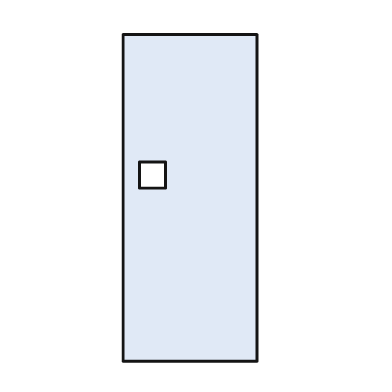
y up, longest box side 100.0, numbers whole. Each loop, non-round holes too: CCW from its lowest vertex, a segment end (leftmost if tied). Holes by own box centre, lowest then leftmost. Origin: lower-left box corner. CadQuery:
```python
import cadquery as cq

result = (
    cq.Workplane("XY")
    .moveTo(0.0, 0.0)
    .lineTo(41.0, 0.0)
    .lineTo(41.0, 100.0)
    .lineTo(0.0, 100.0)
    .close()
    .moveTo(5.0, 53.0)
    .lineTo(13.0, 53.0)
    .lineTo(13.0, 61.0)
    .lineTo(5.0, 61.0)
    .close()
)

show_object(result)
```